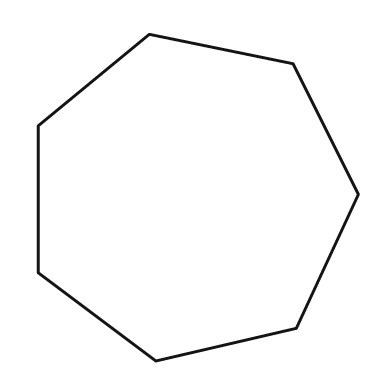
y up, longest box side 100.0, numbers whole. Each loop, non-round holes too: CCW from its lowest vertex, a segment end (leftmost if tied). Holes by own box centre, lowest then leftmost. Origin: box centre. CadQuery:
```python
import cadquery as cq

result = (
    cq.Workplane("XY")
    .moveTo(-13.0, -50.0)
    .lineTo(30.0, -40.0)
    .lineTo(49.0, 1.0)
    .lineTo(29.0, 41.0)
    .lineTo(-15.0, 50.0)
    .lineTo(-49.0, 22.0)
    .lineTo(-49.0, -23.0)
    .close()
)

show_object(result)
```